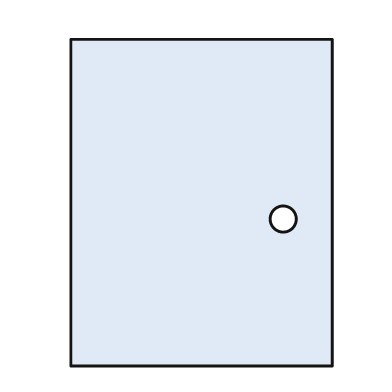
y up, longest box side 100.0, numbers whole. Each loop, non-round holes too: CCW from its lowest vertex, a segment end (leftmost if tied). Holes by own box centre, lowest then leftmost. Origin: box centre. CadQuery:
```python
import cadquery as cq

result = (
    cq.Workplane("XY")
    .moveTo(-40.0, -50.0)
    .lineTo(40.0, -50.0)
    .lineTo(40.0, 50.0)
    .lineTo(-40.0, 50.0)
    .close()
    .moveTo(25.0, -5.0)
    .circle(4.0)
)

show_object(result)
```